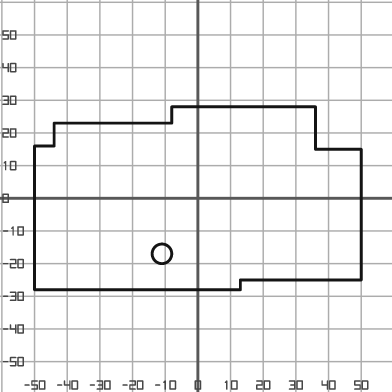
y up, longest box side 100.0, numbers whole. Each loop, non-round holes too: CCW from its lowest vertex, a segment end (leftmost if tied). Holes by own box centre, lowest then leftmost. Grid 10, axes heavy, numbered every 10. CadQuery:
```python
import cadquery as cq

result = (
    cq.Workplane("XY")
    .moveTo(-50.0, -28.0)
    .lineTo(13.0, -28.0)
    .lineTo(13.0, -25.0)
    .lineTo(50.0, -25.0)
    .lineTo(50.0, 15.0)
    .lineTo(36.0, 15.0)
    .lineTo(36.0, 28.0)
    .lineTo(-8.0, 28.0)
    .lineTo(-8.0, 23.0)
    .lineTo(-44.0, 23.0)
    .lineTo(-44.0, 16.0)
    .lineTo(-50.0, 16.0)
    .close()
    .moveTo(-11.0, -17.0)
    .circle(3.0)
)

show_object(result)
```